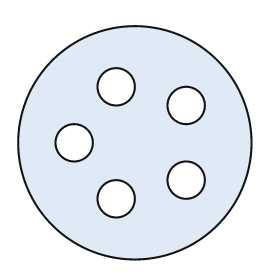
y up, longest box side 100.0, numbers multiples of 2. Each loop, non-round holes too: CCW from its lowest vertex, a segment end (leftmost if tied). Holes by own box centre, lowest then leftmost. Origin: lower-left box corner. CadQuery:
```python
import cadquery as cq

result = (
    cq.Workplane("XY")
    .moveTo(50.0, 50.0)
    .circle(50.0)
    .moveTo(42.0, 26.0)
    .circle(8.0)
    .moveTo(72.0, 34.0)
    .circle(8.0)
    .moveTo(24.0, 50.0)
    .circle(8.0)
    .moveTo(72.0, 66.0)
    .circle(8.0)
    .moveTo(42.0, 74.0)
    .circle(8.0)
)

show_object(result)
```